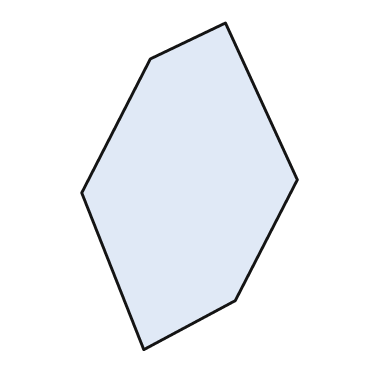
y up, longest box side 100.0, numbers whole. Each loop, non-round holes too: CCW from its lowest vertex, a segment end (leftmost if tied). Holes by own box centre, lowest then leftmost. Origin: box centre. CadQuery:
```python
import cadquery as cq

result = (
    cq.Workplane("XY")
    .moveTo(-14.0, -50.0)
    .lineTo(14.0, -35.0)
    .lineTo(33.0, 2.0)
    .lineTo(11.0, 50.0)
    .lineTo(-12.0, 39.0)
    .lineTo(-33.0, -2.0)
    .close()
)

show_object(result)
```